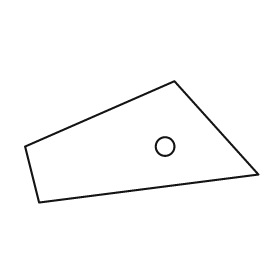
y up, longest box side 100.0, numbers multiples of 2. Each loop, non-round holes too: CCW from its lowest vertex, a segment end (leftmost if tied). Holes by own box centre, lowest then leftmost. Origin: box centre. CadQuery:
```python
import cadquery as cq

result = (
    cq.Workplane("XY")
    .moveTo(-44.0, -26.0)
    .lineTo(50.0, -14.0)
    .lineTo(14.0, 26.0)
    .lineTo(-50.0, -2.0)
    .close()
    .moveTo(10.0, -2.0)
    .circle(4.0)
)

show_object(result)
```